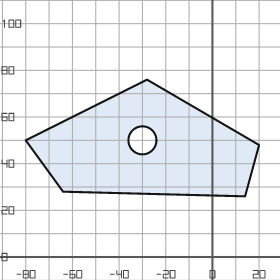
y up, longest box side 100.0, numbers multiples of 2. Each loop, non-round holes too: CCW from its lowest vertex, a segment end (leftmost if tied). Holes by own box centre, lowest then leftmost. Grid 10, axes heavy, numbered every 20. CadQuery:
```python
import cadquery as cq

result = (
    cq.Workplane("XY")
    .moveTo(14.0, 26.0)
    .lineTo(20.0, 48.0)
    .lineTo(-28.0, 76.0)
    .lineTo(-80.0, 50.0)
    .lineTo(-64.0, 28.0)
    .close()
    .moveTo(-30.0, 50.0)
    .circle(6.0)
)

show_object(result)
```